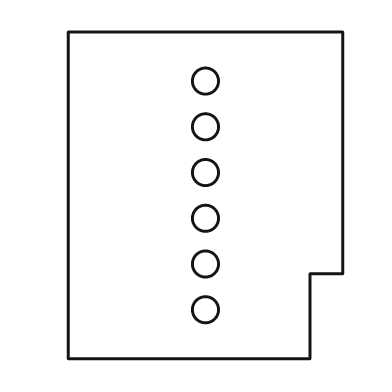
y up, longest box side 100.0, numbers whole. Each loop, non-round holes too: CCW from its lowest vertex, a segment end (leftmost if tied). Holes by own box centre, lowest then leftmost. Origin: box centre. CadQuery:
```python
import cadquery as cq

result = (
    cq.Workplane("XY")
    .moveTo(-42.0, -50.0)
    .lineTo(32.0, -50.0)
    .lineTo(32.0, -24.0)
    .lineTo(42.0, -24.0)
    .lineTo(42.0, 50.0)
    .lineTo(-42.0, 50.0)
    .close()
    .moveTo(0.0, -35.0)
    .circle(4.0)
    .moveTo(0.0, -21.0)
    .circle(4.0)
    .moveTo(0.0, -7.0)
    .circle(4.0)
    .moveTo(0.0, 7.0)
    .circle(4.0)
    .moveTo(0.0, 21.0)
    .circle(4.0)
    .moveTo(0.0, 35.0)
    .circle(4.0)
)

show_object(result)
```